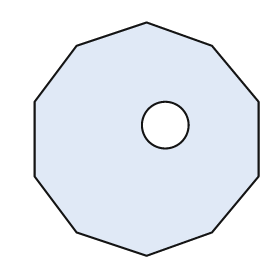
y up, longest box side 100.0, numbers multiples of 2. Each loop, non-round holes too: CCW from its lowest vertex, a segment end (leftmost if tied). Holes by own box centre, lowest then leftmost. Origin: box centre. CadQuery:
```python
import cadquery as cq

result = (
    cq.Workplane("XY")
    .moveTo(0.0, -50.0)
    .lineTo(28.0, -40.0)
    .lineTo(48.0, -16.0)
    .lineTo(48.0, 16.0)
    .lineTo(28.0, 40.0)
    .lineTo(0.0, 50.0)
    .lineTo(-30.0, 40.0)
    .lineTo(-48.0, 16.0)
    .lineTo(-48.0, -16.0)
    .lineTo(-30.0, -40.0)
    .close()
    .moveTo(8.0, 6.0)
    .circle(10.0)
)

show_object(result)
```